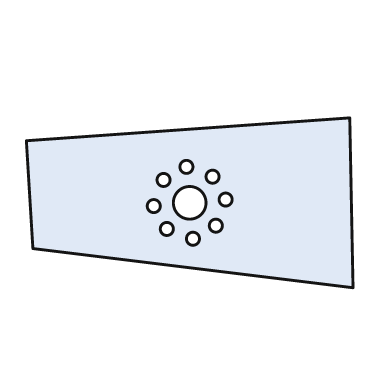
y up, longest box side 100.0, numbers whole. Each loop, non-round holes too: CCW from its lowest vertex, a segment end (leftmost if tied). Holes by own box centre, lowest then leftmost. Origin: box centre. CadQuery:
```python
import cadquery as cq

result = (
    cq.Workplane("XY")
    .moveTo(50.0, -26.0)
    .lineTo(49.0, 26.0)
    .lineTo(-50.0, 19.0)
    .lineTo(-48.0, -14.0)
    .close()
    .moveTo(1.0, -11.0)
    .circle(2.0)
    .moveTo(-7.0, -8.0)
    .circle(2.0)
    .moveTo(8.0, -7.0)
    .circle(2.0)
    .moveTo(-11.0, -1.0)
    .circle(2.0)
    .moveTo(0.0, 0.0)
    .circle(5.0)
    .moveTo(11.0, 1.0)
    .circle(2.0)
    .moveTo(-8.0, 7.0)
    .circle(2.0)
    .moveTo(7.0, 8.0)
    .circle(2.0)
    .moveTo(-1.0, 11.0)
    .circle(2.0)
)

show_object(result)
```